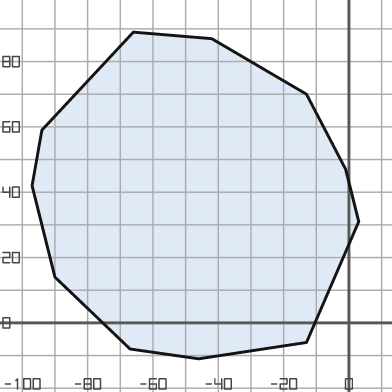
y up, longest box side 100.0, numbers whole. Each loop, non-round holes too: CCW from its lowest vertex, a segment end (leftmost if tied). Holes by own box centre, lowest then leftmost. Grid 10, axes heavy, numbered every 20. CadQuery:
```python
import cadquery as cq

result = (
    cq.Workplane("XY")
    .moveTo(-46.0, -11.0)
    .lineTo(-13.0, -6.0)
    .lineTo(3.0, 31.0)
    .lineTo(-1.0, 47.0)
    .lineTo(-13.0, 70.0)
    .lineTo(-42.0, 87.0)
    .lineTo(-66.0, 89.0)
    .lineTo(-94.0, 59.0)
    .lineTo(-97.0, 42.0)
    .lineTo(-90.0, 14.0)
    .lineTo(-67.0, -8.0)
    .close()
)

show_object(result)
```